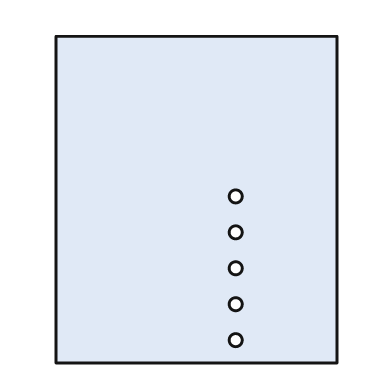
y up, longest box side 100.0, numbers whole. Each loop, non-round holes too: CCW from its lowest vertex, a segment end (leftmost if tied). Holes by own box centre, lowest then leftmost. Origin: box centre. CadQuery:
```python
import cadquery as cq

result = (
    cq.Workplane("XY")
    .moveTo(-43.0, -50.0)
    .lineTo(43.0, -50.0)
    .lineTo(43.0, 50.0)
    .lineTo(-43.0, 50.0)
    .close()
    .moveTo(12.0, -43.0)
    .circle(2.0)
    .moveTo(12.0, -32.0)
    .circle(2.0)
    .moveTo(12.0, -21.0)
    .circle(2.0)
    .moveTo(12.0, -10.0)
    .circle(2.0)
    .moveTo(12.0, 1.0)
    .circle(2.0)
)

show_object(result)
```